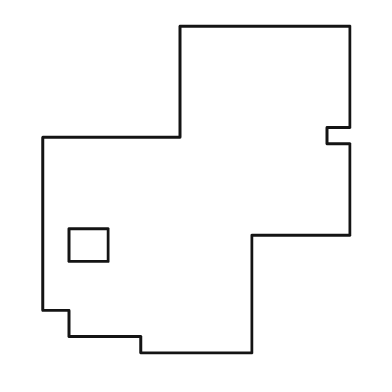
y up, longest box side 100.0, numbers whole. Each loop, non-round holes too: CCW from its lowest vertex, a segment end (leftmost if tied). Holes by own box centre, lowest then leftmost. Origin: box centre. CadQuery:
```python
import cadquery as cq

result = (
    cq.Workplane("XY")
    .moveTo(-17.0, -50.0)
    .lineTo(17.0, -50.0)
    .lineTo(17.0, -14.0)
    .lineTo(47.0, -14.0)
    .lineTo(47.0, 14.0)
    .lineTo(40.0, 14.0)
    .lineTo(40.0, 19.0)
    .lineTo(47.0, 19.0)
    .lineTo(47.0, 50.0)
    .lineTo(-5.0, 50.0)
    .lineTo(-5.0, 16.0)
    .lineTo(-47.0, 16.0)
    .lineTo(-47.0, -37.0)
    .lineTo(-39.0, -37.0)
    .lineTo(-39.0, -45.0)
    .lineTo(-17.0, -45.0)
    .close()
    .moveTo(-39.0, -22.0)
    .lineTo(-27.0, -22.0)
    .lineTo(-27.0, -12.0)
    .lineTo(-39.0, -12.0)
    .close()
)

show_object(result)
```